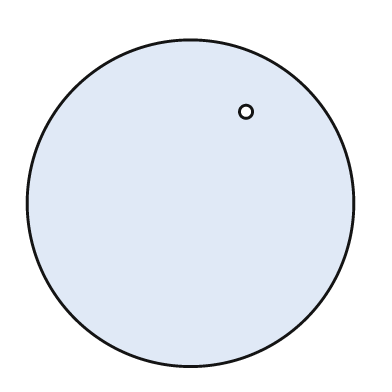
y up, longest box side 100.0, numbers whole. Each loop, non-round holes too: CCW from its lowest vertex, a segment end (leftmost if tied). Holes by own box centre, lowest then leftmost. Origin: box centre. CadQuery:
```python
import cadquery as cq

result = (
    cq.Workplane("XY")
    .moveTo(0.0, 0.0)
    .circle(50.0)
    .moveTo(17.0, 28.0)
    .circle(2.0)
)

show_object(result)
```